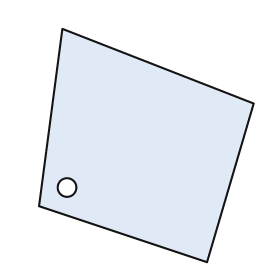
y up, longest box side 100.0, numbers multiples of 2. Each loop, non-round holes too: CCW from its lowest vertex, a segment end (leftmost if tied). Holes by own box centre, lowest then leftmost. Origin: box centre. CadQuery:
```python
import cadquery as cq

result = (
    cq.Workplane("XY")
    .moveTo(26.0, -50.0)
    .lineTo(46.0, 18.0)
    .lineTo(-36.0, 50.0)
    .lineTo(-46.0, -26.0)
    .close()
    .moveTo(-34.0, -18.0)
    .circle(4.0)
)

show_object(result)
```